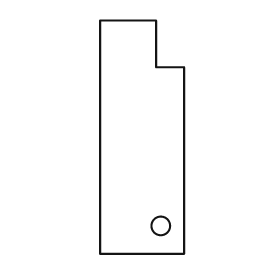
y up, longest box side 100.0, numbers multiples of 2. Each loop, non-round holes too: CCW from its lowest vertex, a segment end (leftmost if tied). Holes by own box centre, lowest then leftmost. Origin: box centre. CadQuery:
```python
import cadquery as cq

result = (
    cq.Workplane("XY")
    .moveTo(-18.0, -50.0)
    .lineTo(18.0, -50.0)
    .lineTo(18.0, 30.0)
    .lineTo(6.0, 30.0)
    .lineTo(6.0, 50.0)
    .lineTo(-18.0, 50.0)
    .close()
    .moveTo(8.0, -38.0)
    .circle(4.0)
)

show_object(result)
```